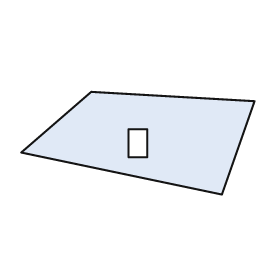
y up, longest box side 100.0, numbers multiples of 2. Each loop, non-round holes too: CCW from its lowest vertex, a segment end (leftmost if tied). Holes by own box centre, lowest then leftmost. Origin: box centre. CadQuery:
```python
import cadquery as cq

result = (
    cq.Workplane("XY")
    .moveTo(36.0, -22.0)
    .lineTo(50.0, 18.0)
    .lineTo(-20.0, 22.0)
    .lineTo(-50.0, -4.0)
    .close()
    .moveTo(-4.0, -6.0)
    .lineTo(4.0, -6.0)
    .lineTo(4.0, 6.0)
    .lineTo(-4.0, 6.0)
    .close()
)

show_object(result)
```